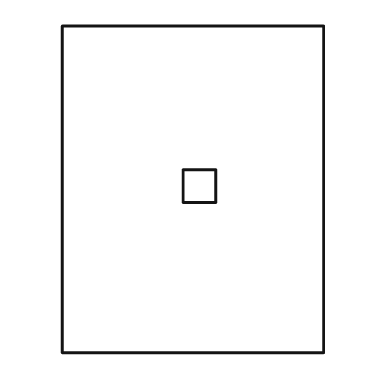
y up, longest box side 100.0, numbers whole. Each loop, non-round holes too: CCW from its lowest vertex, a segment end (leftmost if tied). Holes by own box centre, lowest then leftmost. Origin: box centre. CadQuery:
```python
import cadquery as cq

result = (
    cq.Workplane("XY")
    .moveTo(-40.0, -50.0)
    .lineTo(40.0, -50.0)
    .lineTo(40.0, 50.0)
    .lineTo(-40.0, 50.0)
    .close()
    .moveTo(-3.0, -4.0)
    .lineTo(7.0, -4.0)
    .lineTo(7.0, 6.0)
    .lineTo(-3.0, 6.0)
    .close()
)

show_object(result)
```